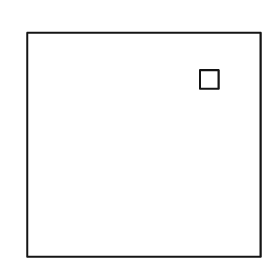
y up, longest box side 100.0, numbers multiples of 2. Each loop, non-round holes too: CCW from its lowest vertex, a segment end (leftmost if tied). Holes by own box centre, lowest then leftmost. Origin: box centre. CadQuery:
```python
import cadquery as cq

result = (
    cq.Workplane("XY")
    .moveTo(-50.0, -48.0)
    .lineTo(50.0, -48.0)
    .lineTo(50.0, 48.0)
    .lineTo(-50.0, 48.0)
    .close()
    .moveTo(24.0, 24.0)
    .lineTo(32.0, 24.0)
    .lineTo(32.0, 32.0)
    .lineTo(24.0, 32.0)
    .close()
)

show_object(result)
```